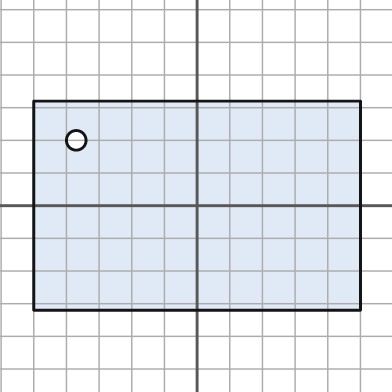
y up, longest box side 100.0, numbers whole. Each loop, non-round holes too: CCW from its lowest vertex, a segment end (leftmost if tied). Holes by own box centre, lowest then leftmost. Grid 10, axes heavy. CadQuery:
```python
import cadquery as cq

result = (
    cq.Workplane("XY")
    .moveTo(-50.0, -32.0)
    .lineTo(50.0, -32.0)
    .lineTo(50.0, 32.0)
    .lineTo(-50.0, 32.0)
    .close()
    .moveTo(-37.0, 20.0)
    .circle(3.0)
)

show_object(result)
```